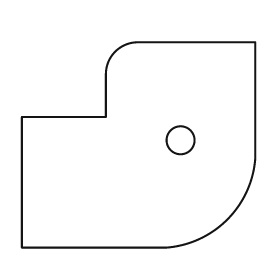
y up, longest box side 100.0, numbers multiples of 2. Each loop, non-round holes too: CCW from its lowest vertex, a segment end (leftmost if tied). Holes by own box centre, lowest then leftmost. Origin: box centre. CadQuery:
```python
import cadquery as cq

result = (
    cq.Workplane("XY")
    .moveTo(-50.0, -44.0)
    .lineTo(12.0, -44.0)
    .threePointArc((38.0, -32.0), (50.0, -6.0))
    .lineTo(50.0, 44.0)
    .lineTo(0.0, 44.0)
    .threePointArc((-10.0, 40.0), (-14.0, 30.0))
    .lineTo(-14.0, 12.0)
    .lineTo(-50.0, 12.0)
    .close()
    .moveTo(18.0, 2.0)
    .circle(6.0)
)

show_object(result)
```